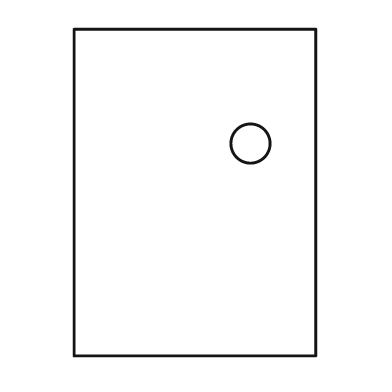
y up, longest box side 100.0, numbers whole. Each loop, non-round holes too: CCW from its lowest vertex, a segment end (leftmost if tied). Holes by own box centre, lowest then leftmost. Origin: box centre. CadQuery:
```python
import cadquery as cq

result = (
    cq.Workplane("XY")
    .moveTo(-37.0, -50.0)
    .lineTo(37.0, -50.0)
    .lineTo(37.0, 50.0)
    .lineTo(-37.0, 50.0)
    .close()
    .moveTo(17.0, 15.0)
    .circle(6.0)
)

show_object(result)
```